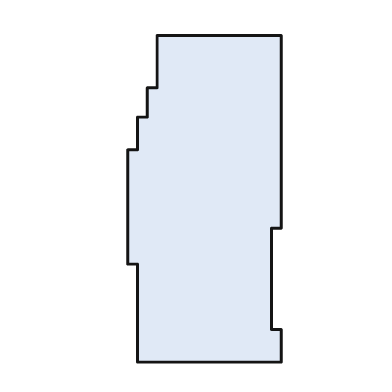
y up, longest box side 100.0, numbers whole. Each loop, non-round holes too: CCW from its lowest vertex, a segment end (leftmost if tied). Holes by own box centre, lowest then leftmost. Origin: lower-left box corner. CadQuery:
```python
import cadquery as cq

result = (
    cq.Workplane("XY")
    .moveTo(3.0, 0.0)
    .lineTo(47.0, 0.0)
    .lineTo(47.0, 10.0)
    .lineTo(44.0, 10.0)
    .lineTo(44.0, 41.0)
    .lineTo(47.0, 41.0)
    .lineTo(47.0, 100.0)
    .lineTo(9.0, 100.0)
    .lineTo(9.0, 84.0)
    .lineTo(6.0, 84.0)
    .lineTo(6.0, 75.0)
    .lineTo(3.0, 75.0)
    .lineTo(3.0, 65.0)
    .lineTo(0.0, 65.0)
    .lineTo(0.0, 30.0)
    .lineTo(3.0, 30.0)
    .close()
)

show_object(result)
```